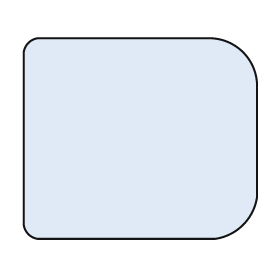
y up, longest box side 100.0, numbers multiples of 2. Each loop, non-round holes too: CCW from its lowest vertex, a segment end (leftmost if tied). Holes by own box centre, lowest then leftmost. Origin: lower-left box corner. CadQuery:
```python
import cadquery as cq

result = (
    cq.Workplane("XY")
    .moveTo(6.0, 0.0)
    .lineTo(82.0, 0.0)
    .threePointArc((94.0, 6.0), (100.0, 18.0))
    .lineTo(100.0, 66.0)
    .threePointArc((94.0, 80.0), (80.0, 86.0))
    .lineTo(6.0, 86.0)
    .threePointArc((2.0, 84.0), (0.0, 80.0))
    .lineTo(0.0, 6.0)
    .threePointArc((2.0, 2.0), (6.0, 0.0))
    .close()
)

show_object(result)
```